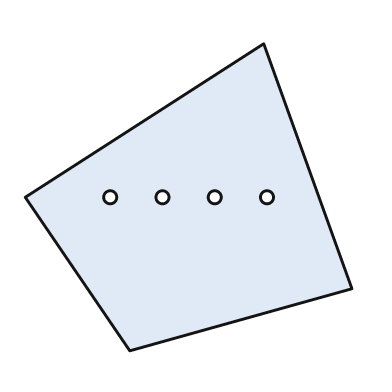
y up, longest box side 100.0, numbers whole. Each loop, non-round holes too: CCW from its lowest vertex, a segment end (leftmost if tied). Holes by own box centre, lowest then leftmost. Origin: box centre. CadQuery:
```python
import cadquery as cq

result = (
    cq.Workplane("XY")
    .moveTo(-18.0, -47.0)
    .lineTo(50.0, -28.0)
    .lineTo(23.0, 47.0)
    .lineTo(-50.0, 0.0)
    .close()
    .moveTo(-24.0, 0.0)
    .circle(2.0)
    .moveTo(-8.0, 0.0)
    .circle(2.0)
    .moveTo(8.0, 0.0)
    .circle(2.0)
    .moveTo(24.0, 0.0)
    .circle(2.0)
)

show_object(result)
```